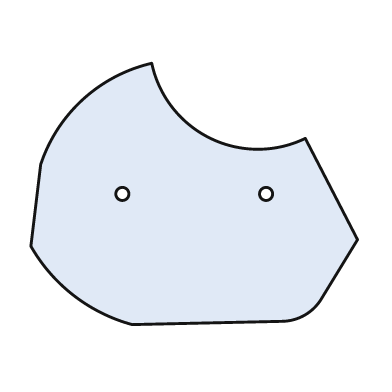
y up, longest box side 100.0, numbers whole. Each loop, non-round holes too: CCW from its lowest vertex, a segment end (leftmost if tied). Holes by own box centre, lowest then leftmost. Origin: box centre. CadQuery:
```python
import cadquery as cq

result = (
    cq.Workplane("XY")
    .moveTo(-19.0, -40.0)
    .lineTo(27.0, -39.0)
    .threePointArc((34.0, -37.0), (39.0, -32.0))
    .lineTo(50.0, -14.0)
    .lineTo(34.0, 17.0)
    .threePointArc((5.0, 17.0), (-13.0, 40.0))
    .threePointArc((-34.0, 29.0), (-47.0, 9.0))
    .lineTo(-50.0, -16.0)
    .threePointArc((-37.0, -31.0), (-19.0, -40.0))
    .close()
    .moveTo(-22.0, 0.0)
    .circle(2.0)
    .moveTo(22.0, 0.0)
    .circle(2.0)
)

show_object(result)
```